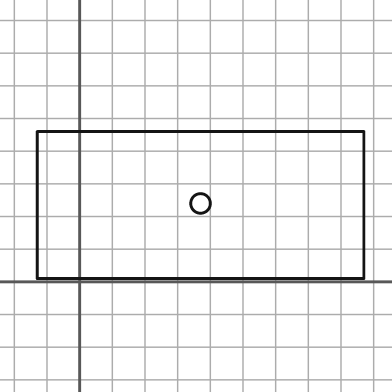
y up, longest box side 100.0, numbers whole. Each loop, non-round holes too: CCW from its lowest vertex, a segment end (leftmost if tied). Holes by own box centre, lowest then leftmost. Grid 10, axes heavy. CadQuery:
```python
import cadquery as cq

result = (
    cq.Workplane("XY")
    .moveTo(-13.0, 1.0)
    .lineTo(87.0, 1.0)
    .lineTo(87.0, 46.0)
    .lineTo(-13.0, 46.0)
    .close()
    .moveTo(37.0, 24.0)
    .circle(3.0)
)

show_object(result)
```